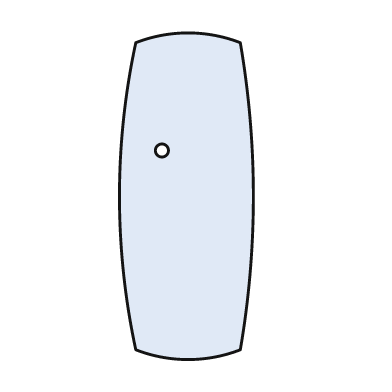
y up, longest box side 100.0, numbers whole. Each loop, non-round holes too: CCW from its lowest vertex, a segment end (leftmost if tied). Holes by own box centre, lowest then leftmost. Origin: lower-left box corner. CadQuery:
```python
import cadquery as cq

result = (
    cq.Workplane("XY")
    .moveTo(5.0, 3.0)
    .threePointArc((21.0, 0.0), (37.0, 3.0))
    .threePointArc((41.0, 50.0), (37.0, 97.0))
    .threePointArc((21.0, 100.0), (5.0, 97.0))
    .threePointArc((0.0, 50.0), (5.0, 3.0))
    .close()
    .moveTo(13.0, 64.0)
    .circle(2.0)
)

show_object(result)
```